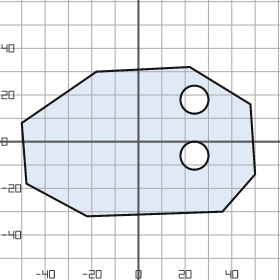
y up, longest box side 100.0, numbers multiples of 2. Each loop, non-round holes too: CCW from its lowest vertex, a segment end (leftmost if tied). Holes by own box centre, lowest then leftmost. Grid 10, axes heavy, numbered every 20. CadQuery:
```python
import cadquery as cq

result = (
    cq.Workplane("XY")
    .moveTo(-22.0, -32.0)
    .lineTo(36.0, -30.0)
    .lineTo(50.0, -14.0)
    .lineTo(48.0, 16.0)
    .lineTo(22.0, 32.0)
    .lineTo(-18.0, 30.0)
    .lineTo(-50.0, 8.0)
    .lineTo(-48.0, -18.0)
    .close()
    .moveTo(24.0, -6.0)
    .circle(6.0)
    .moveTo(24.0, 18.0)
    .circle(6.0)
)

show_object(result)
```